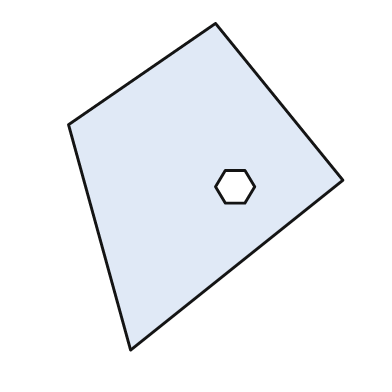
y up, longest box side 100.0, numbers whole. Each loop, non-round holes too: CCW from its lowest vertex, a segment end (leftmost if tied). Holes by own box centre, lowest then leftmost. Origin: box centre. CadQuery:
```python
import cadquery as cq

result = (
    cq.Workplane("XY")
    .moveTo(-23.0, -50.0)
    .lineTo(42.0, 2.0)
    .lineTo(3.0, 50.0)
    .lineTo(-42.0, 19.0)
    .close()
    .moveTo(6.0, -5.0)
    .lineTo(12.0, -5.0)
    .lineTo(15.0, 0.0)
    .lineTo(12.0, 5.0)
    .lineTo(6.0, 5.0)
    .lineTo(3.0, 0.0)
    .close()
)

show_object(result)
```